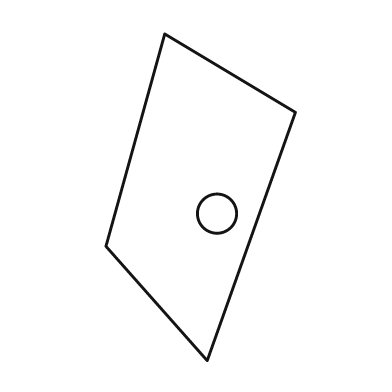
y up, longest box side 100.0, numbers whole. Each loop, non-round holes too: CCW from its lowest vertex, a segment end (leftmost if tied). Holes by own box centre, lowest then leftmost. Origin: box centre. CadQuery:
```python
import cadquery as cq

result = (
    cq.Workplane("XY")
    .moveTo(2.0, -50.0)
    .lineTo(29.0, 26.0)
    .lineTo(-11.0, 50.0)
    .lineTo(-29.0, -15.0)
    .close()
    .moveTo(5.0, -5.0)
    .circle(6.0)
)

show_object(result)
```